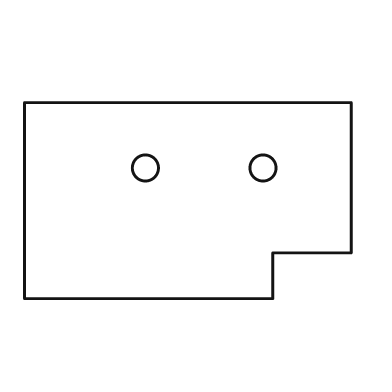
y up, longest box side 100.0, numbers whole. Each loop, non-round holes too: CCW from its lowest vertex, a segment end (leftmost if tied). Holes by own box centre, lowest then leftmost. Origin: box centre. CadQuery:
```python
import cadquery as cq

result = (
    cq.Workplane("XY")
    .moveTo(-50.0, -30.0)
    .lineTo(26.0, -30.0)
    .lineTo(26.0, -16.0)
    .lineTo(50.0, -16.0)
    .lineTo(50.0, 30.0)
    .lineTo(-50.0, 30.0)
    .close()
    .moveTo(-13.0, 10.0)
    .circle(4.0)
    .moveTo(23.0, 10.0)
    .circle(4.0)
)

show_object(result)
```